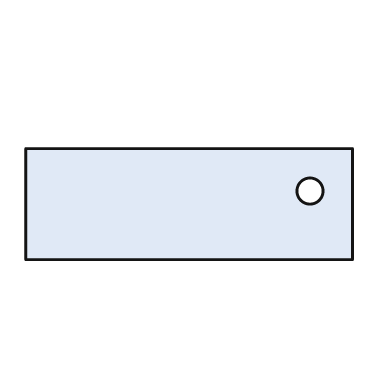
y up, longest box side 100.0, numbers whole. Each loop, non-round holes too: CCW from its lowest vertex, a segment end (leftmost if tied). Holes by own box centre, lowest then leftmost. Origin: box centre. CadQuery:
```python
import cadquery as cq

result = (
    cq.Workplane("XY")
    .moveTo(-50.0, -17.0)
    .lineTo(50.0, -17.0)
    .lineTo(50.0, 17.0)
    .lineTo(-50.0, 17.0)
    .close()
    .moveTo(37.0, 4.0)
    .circle(4.0)
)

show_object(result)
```